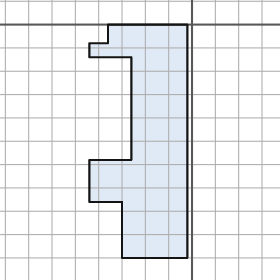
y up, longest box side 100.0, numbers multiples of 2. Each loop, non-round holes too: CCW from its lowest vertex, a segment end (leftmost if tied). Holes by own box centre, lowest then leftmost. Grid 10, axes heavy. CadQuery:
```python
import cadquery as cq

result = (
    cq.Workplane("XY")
    .moveTo(-30.0, -100.0)
    .lineTo(-2.0, -100.0)
    .lineTo(-2.0, 0.0)
    .lineTo(-36.0, 0.0)
    .lineTo(-36.0, -8.0)
    .lineTo(-44.0, -8.0)
    .lineTo(-44.0, -14.0)
    .lineTo(-26.0, -14.0)
    .lineTo(-26.0, -58.0)
    .lineTo(-44.0, -58.0)
    .lineTo(-44.0, -76.0)
    .lineTo(-30.0, -76.0)
    .close()
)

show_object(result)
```